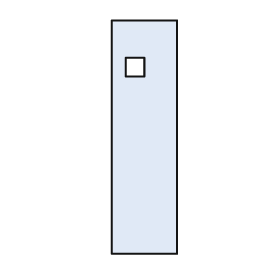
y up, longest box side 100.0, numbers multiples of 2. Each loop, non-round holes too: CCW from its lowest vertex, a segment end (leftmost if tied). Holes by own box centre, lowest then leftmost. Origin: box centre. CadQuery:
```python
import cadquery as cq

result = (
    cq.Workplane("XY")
    .moveTo(-14.0, -50.0)
    .lineTo(14.0, -50.0)
    .lineTo(14.0, 50.0)
    .lineTo(-14.0, 50.0)
    .close()
    .moveTo(-8.0, 26.0)
    .lineTo(0.0, 26.0)
    .lineTo(0.0, 34.0)
    .lineTo(-8.0, 34.0)
    .close()
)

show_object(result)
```